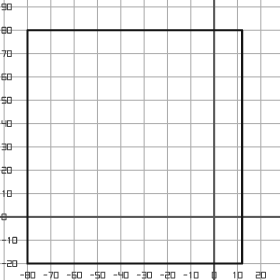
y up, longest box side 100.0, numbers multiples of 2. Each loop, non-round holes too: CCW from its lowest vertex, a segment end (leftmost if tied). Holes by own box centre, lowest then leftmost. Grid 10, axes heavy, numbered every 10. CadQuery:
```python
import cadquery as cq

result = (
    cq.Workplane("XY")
    .moveTo(-80.0, -20.0)
    .lineTo(12.0, -20.0)
    .lineTo(12.0, 80.0)
    .lineTo(-80.0, 80.0)
    .close()
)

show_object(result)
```